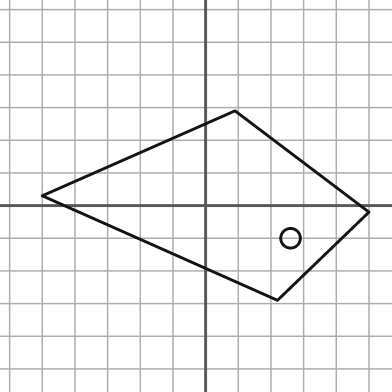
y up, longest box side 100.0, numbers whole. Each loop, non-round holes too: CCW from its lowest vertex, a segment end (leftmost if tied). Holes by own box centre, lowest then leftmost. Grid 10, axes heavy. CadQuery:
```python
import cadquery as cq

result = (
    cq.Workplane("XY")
    .moveTo(22.0, -29.0)
    .lineTo(50.0, -2.0)
    .lineTo(9.0, 29.0)
    .lineTo(-50.0, 3.0)
    .close()
    .moveTo(26.0, -10.0)
    .circle(3.0)
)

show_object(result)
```